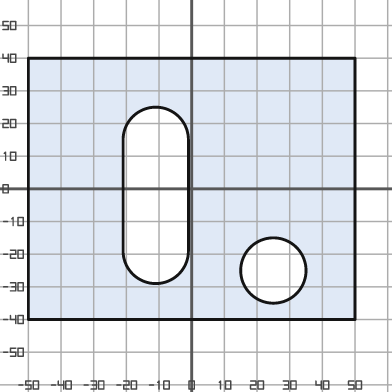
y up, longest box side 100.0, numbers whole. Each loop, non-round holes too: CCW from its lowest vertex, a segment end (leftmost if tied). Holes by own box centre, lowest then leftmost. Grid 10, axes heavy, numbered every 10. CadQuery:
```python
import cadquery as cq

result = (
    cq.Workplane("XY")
    .moveTo(-50.0, -40.0)
    .lineTo(50.0, -40.0)
    .lineTo(50.0, 40.0)
    .lineTo(-50.0, 40.0)
    .close()
    .moveTo(25.0, -25.0)
    .circle(10.0)
    .moveTo(-21.0, -19.0)
    .threePointArc((-11.0, -29.0), (-1.0, -19.0))
    .lineTo(-1.0, 15.0)
    .threePointArc((-11.0, 25.0), (-21.0, 15.0))
    .close()
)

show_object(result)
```